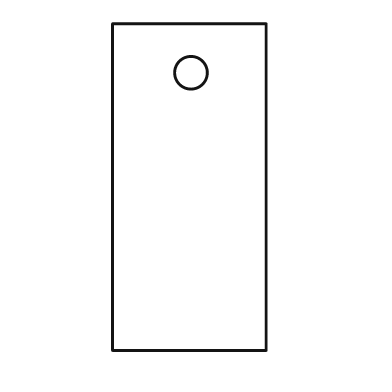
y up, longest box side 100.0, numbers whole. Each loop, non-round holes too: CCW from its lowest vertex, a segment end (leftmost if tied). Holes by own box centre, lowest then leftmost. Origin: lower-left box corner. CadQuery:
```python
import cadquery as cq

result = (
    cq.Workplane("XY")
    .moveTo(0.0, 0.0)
    .lineTo(47.0, 0.0)
    .lineTo(47.0, 100.0)
    .lineTo(0.0, 100.0)
    .close()
    .moveTo(24.0, 85.0)
    .circle(5.0)
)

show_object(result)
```